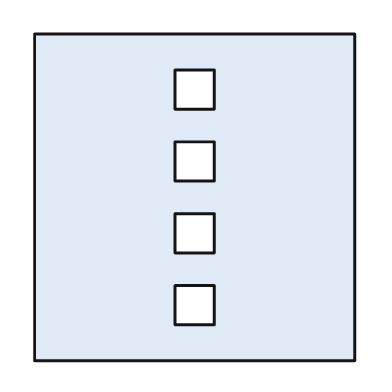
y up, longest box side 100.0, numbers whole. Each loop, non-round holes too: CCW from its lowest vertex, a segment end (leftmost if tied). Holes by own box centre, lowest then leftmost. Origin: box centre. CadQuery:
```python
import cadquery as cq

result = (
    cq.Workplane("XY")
    .moveTo(-49.0, -50.0)
    .lineTo(49.0, -50.0)
    .lineTo(49.0, 50.0)
    .lineTo(-49.0, 50.0)
    .close()
    .moveTo(-6.0, -39.0)
    .lineTo(6.0, -39.0)
    .lineTo(6.0, -27.0)
    .lineTo(-6.0, -27.0)
    .close()
    .moveTo(-6.0, -17.0)
    .lineTo(6.0, -17.0)
    .lineTo(6.0, -5.0)
    .lineTo(-6.0, -5.0)
    .close()
    .moveTo(-6.0, 5.0)
    .lineTo(6.0, 5.0)
    .lineTo(6.0, 17.0)
    .lineTo(-6.0, 17.0)
    .close()
    .moveTo(-6.0, 27.0)
    .lineTo(6.0, 27.0)
    .lineTo(6.0, 39.0)
    .lineTo(-6.0, 39.0)
    .close()
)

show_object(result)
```